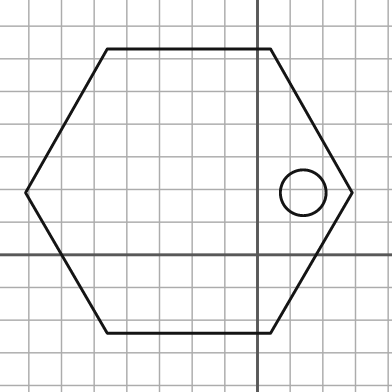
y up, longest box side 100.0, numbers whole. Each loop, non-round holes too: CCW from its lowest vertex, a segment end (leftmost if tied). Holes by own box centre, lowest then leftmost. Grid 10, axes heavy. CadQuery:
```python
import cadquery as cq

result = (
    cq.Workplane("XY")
    .moveTo(-46.0, -24.0)
    .lineTo(4.0, -24.0)
    .lineTo(29.0, 19.0)
    .lineTo(4.0, 63.0)
    .lineTo(-46.0, 63.0)
    .lineTo(-71.0, 19.0)
    .close()
    .moveTo(14.0, 19.0)
    .circle(7.0)
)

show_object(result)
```